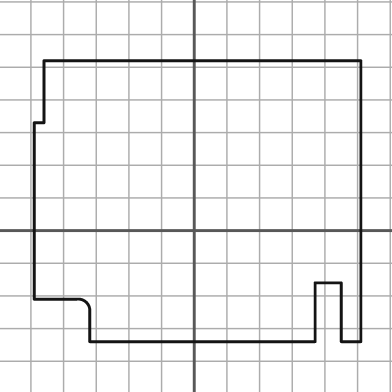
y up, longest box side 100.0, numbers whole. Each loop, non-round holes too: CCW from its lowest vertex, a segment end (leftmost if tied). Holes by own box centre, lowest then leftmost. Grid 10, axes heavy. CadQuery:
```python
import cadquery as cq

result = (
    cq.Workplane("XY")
    .moveTo(-32.0, -34.0)
    .lineTo(37.0, -34.0)
    .lineTo(37.0, -16.0)
    .lineTo(45.0, -16.0)
    .lineTo(45.0, -34.0)
    .lineTo(51.0, -34.0)
    .lineTo(51.0, 52.0)
    .lineTo(-46.0, 52.0)
    .lineTo(-46.0, 33.0)
    .lineTo(-49.0, 33.0)
    .lineTo(-49.0, -21.0)
    .lineTo(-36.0, -21.0)
    .threePointArc((-33.0, -22.0), (-32.0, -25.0))
    .close()
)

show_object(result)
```